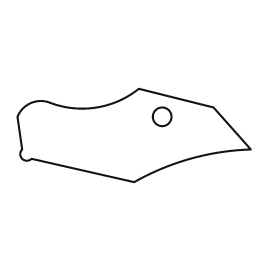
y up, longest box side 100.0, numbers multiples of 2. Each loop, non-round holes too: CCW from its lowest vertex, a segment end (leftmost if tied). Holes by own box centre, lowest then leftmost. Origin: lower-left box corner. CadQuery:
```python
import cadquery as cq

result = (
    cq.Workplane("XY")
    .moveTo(50.0, 0.0)
    .threePointArc((74.0, 10.0), (100.0, 14.0))
    .lineTo(84.0, 32.0)
    .lineTo(52.0, 40.0)
    .threePointArc((34.0, 32.0), (14.0, 34.0))
    .threePointArc((6.0, 34.0), (0.0, 28.0))
    .lineTo(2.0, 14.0)
    .threePointArc((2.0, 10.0), (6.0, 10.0))
    .close()
    .moveTo(62.0, 28.0)
    .circle(4.0)
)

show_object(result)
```